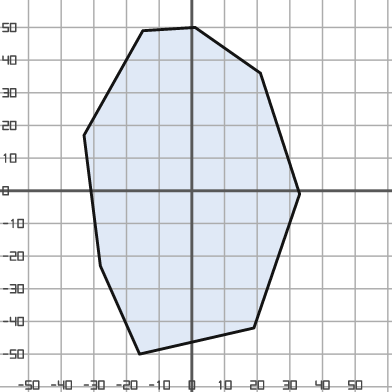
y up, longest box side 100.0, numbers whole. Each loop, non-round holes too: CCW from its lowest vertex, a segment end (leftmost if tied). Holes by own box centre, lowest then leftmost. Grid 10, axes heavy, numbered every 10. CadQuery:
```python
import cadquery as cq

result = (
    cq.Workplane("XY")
    .moveTo(-16.0, -50.0)
    .lineTo(19.0, -42.0)
    .lineTo(33.0, -1.0)
    .lineTo(21.0, 36.0)
    .lineTo(1.0, 50.0)
    .lineTo(-15.0, 49.0)
    .lineTo(-33.0, 17.0)
    .lineTo(-28.0, -23.0)
    .close()
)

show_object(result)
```